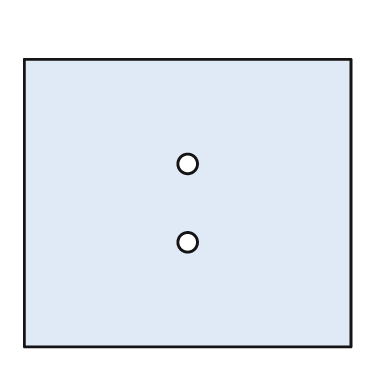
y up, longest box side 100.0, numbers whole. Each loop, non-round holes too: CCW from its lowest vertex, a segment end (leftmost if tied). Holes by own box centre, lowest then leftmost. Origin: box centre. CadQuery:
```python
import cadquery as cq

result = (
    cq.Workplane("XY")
    .moveTo(-50.0, -44.0)
    .lineTo(50.0, -44.0)
    .lineTo(50.0, 44.0)
    .lineTo(-50.0, 44.0)
    .close()
    .moveTo(0.0, -12.0)
    .circle(3.0)
    .moveTo(0.0, 12.0)
    .circle(3.0)
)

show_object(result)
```